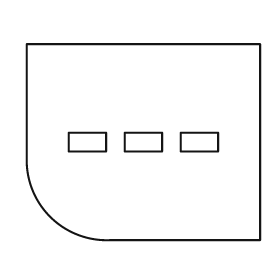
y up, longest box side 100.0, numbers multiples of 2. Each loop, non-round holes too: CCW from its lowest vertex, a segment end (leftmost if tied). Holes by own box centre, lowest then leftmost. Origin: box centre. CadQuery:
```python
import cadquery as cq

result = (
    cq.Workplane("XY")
    .moveTo(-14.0, -42.0)
    .lineTo(50.0, -42.0)
    .lineTo(50.0, 42.0)
    .lineTo(-50.0, 42.0)
    .lineTo(-50.0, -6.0)
    .threePointArc((-40.0, -32.0), (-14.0, -42.0))
    .close()
    .moveTo(-32.0, -4.0)
    .lineTo(-16.0, -4.0)
    .lineTo(-16.0, 4.0)
    .lineTo(-32.0, 4.0)
    .close()
    .moveTo(-8.0, -4.0)
    .lineTo(8.0, -4.0)
    .lineTo(8.0, 4.0)
    .lineTo(-8.0, 4.0)
    .close()
    .moveTo(16.0, -4.0)
    .lineTo(32.0, -4.0)
    .lineTo(32.0, 4.0)
    .lineTo(16.0, 4.0)
    .close()
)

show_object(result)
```